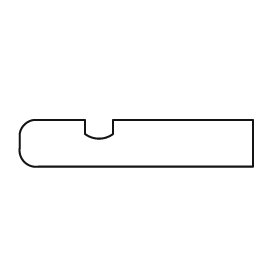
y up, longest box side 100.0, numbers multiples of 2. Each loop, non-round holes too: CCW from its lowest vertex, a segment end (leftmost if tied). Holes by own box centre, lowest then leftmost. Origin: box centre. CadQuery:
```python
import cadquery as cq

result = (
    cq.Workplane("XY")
    .moveTo(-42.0, -10.0)
    .lineTo(50.0, -10.0)
    .lineTo(50.0, 10.0)
    .lineTo(-10.0, 10.0)
    .lineTo(-10.0, 4.0)
    .threePointArc((-16.0, 2.0), (-22.0, 4.0))
    .lineTo(-22.0, 10.0)
    .lineTo(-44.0, 10.0)
    .threePointArc((-48.0, 8.0), (-50.0, 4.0))
    .lineTo(-50.0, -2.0)
    .threePointArc((-48.0, -8.0), (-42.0, -10.0))
    .close()
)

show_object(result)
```